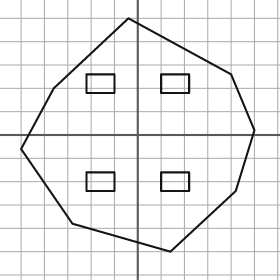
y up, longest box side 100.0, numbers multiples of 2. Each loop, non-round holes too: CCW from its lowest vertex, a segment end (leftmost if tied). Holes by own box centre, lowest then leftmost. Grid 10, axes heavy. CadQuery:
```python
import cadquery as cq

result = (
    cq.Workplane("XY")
    .moveTo(14.0, -50.0)
    .lineTo(42.0, -24.0)
    .lineTo(50.0, 2.0)
    .lineTo(40.0, 26.0)
    .lineTo(-4.0, 50.0)
    .lineTo(-36.0, 20.0)
    .lineTo(-50.0, -6.0)
    .lineTo(-28.0, -38.0)
    .close()
    .moveTo(-22.0, -24.0)
    .lineTo(-10.0, -24.0)
    .lineTo(-10.0, -16.0)
    .lineTo(-22.0, -16.0)
    .close()
    .moveTo(10.0, -24.0)
    .lineTo(22.0, -24.0)
    .lineTo(22.0, -16.0)
    .lineTo(10.0, -16.0)
    .close()
    .moveTo(-22.0, 18.0)
    .lineTo(-10.0, 18.0)
    .lineTo(-10.0, 26.0)
    .lineTo(-22.0, 26.0)
    .close()
    .moveTo(10.0, 18.0)
    .lineTo(22.0, 18.0)
    .lineTo(22.0, 26.0)
    .lineTo(10.0, 26.0)
    .close()
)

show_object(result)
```